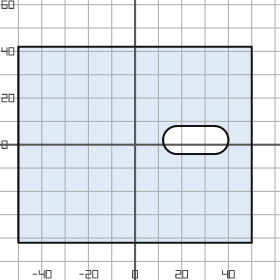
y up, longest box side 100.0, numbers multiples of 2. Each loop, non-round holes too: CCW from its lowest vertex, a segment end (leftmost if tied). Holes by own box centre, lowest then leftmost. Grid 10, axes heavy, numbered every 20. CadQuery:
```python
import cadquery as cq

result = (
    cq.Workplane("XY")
    .moveTo(-50.0, -42.0)
    .lineTo(50.0, -42.0)
    .lineTo(50.0, 42.0)
    .lineTo(-50.0, 42.0)
    .close()
    .moveTo(18.0, -4.0)
    .lineTo(34.0, -4.0)
    .threePointArc((40.0, 2.0), (34.0, 8.0))
    .lineTo(18.0, 8.0)
    .threePointArc((12.0, 2.0), (18.0, -4.0))
    .close()
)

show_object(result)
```